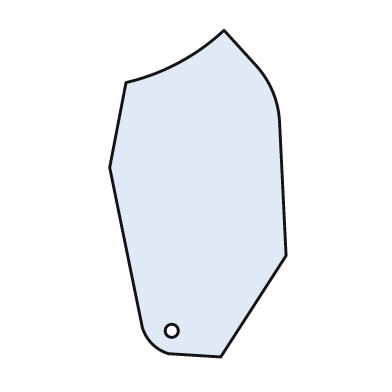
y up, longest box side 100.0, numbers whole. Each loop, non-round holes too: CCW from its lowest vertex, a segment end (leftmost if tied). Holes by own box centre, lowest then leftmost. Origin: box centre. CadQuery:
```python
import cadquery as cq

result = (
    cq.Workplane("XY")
    .moveTo(7.0, -50.0)
    .lineTo(27.0, -19.0)
    .lineTo(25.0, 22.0)
    .threePointArc((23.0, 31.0), (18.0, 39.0))
    .lineTo(8.0, 50.0)
    .threePointArc((-6.0, 40.0), (-22.0, 34.0))
    .lineTo(-27.0, 8.0)
    .lineTo(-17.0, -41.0)
    .threePointArc((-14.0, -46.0), (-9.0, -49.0))
    .close()
    .moveTo(-8.0, -42.0)
    .circle(2.0)
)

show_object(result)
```